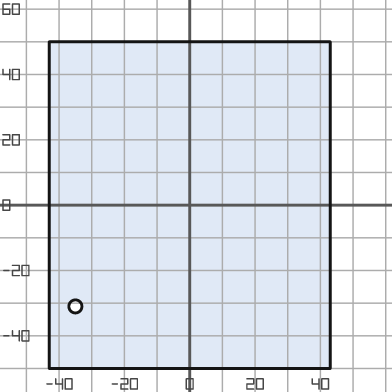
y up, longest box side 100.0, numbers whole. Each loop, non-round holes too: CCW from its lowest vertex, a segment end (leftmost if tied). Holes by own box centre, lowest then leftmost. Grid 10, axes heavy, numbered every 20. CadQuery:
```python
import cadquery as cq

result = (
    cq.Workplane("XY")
    .moveTo(-43.0, -50.0)
    .lineTo(43.0, -50.0)
    .lineTo(43.0, 50.0)
    .lineTo(-43.0, 50.0)
    .close()
    .moveTo(-35.0, -31.0)
    .circle(2.0)
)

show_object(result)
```